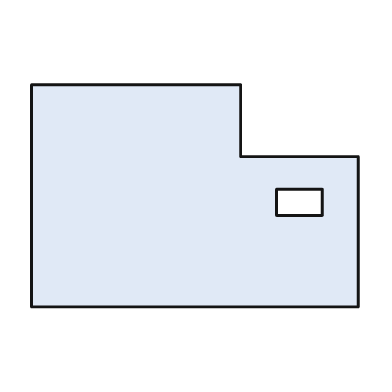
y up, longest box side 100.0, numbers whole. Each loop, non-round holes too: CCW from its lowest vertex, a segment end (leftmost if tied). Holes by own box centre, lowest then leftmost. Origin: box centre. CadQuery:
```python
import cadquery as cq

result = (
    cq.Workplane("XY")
    .moveTo(-50.0, -34.0)
    .lineTo(50.0, -34.0)
    .lineTo(50.0, 12.0)
    .lineTo(14.0, 12.0)
    .lineTo(14.0, 34.0)
    .lineTo(-50.0, 34.0)
    .close()
    .moveTo(25.0, -6.0)
    .lineTo(39.0, -6.0)
    .lineTo(39.0, 2.0)
    .lineTo(25.0, 2.0)
    .close()
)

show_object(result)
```